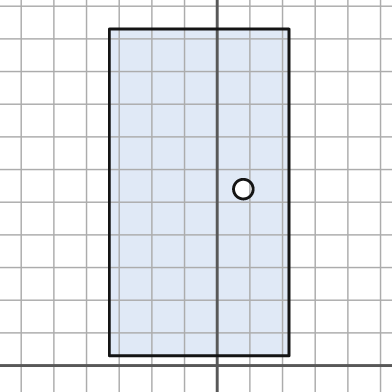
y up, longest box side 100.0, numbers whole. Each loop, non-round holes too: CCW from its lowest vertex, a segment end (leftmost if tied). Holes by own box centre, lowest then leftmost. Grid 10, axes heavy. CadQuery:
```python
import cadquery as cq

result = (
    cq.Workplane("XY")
    .moveTo(-33.0, 3.0)
    .lineTo(22.0, 3.0)
    .lineTo(22.0, 103.0)
    .lineTo(-33.0, 103.0)
    .close()
    .moveTo(8.0, 54.0)
    .circle(3.0)
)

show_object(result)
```